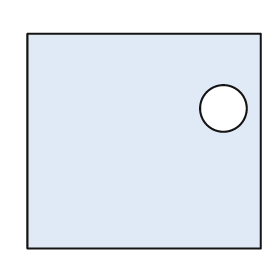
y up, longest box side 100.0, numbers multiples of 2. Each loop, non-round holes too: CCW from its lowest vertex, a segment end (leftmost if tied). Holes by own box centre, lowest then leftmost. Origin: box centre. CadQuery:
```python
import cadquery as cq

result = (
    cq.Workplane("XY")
    .moveTo(-50.0, -46.0)
    .lineTo(50.0, -46.0)
    .lineTo(50.0, 46.0)
    .lineTo(-50.0, 46.0)
    .close()
    .moveTo(34.0, 14.0)
    .circle(10.0)
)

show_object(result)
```